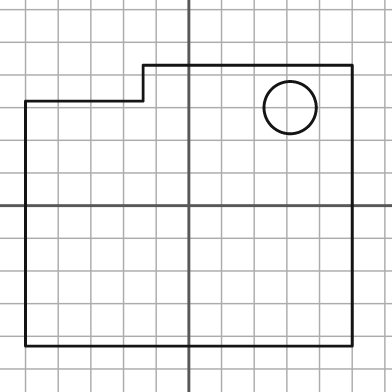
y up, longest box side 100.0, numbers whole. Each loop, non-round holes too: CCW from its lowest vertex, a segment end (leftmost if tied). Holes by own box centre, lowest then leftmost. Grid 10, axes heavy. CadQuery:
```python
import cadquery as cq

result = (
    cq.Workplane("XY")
    .moveTo(-50.0, -43.0)
    .lineTo(50.0, -43.0)
    .lineTo(50.0, 43.0)
    .lineTo(-14.0, 43.0)
    .lineTo(-14.0, 32.0)
    .lineTo(-50.0, 32.0)
    .close()
    .moveTo(31.0, 30.0)
    .circle(8.0)
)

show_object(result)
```